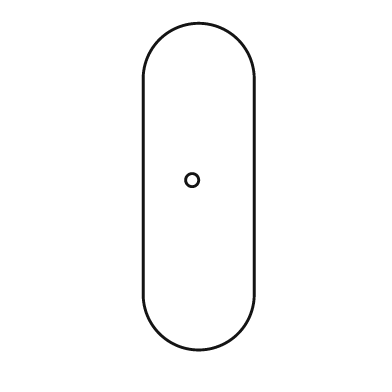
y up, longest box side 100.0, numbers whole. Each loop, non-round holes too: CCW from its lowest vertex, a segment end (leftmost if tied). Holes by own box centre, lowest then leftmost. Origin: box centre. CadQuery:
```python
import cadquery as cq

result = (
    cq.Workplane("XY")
    .moveTo(-17.0, -33.0)
    .threePointArc((0.0, -50.0), (17.0, -33.0))
    .lineTo(17.0, 33.0)
    .threePointArc((0.0, 50.0), (-17.0, 33.0))
    .close()
    .moveTo(-2.0, 2.0)
    .circle(2.0)
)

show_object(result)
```